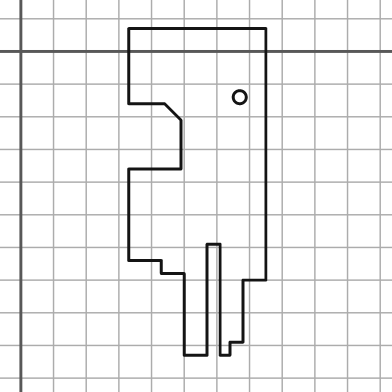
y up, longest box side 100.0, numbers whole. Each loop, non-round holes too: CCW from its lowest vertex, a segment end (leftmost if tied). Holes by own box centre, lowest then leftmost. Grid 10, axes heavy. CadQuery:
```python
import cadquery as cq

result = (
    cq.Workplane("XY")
    .moveTo(50.0, -93.0)
    .lineTo(57.0, -93.0)
    .lineTo(57.0, -59.0)
    .lineTo(61.0, -59.0)
    .lineTo(61.0, -93.0)
    .lineTo(64.0, -93.0)
    .lineTo(64.0, -89.0)
    .lineTo(68.0, -89.0)
    .lineTo(68.0, -70.0)
    .lineTo(75.0, -70.0)
    .lineTo(75.0, 7.0)
    .lineTo(33.0, 7.0)
    .lineTo(33.0, -16.0)
    .lineTo(44.0, -16.0)
    .lineTo(49.0, -21.0)
    .lineTo(49.0, -36.0)
    .lineTo(33.0, -36.0)
    .lineTo(33.0, -64.0)
    .lineTo(43.0, -64.0)
    .lineTo(43.0, -68.0)
    .lineTo(50.0, -68.0)
    .close()
    .moveTo(67.0, -14.0)
    .circle(2.0)
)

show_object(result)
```